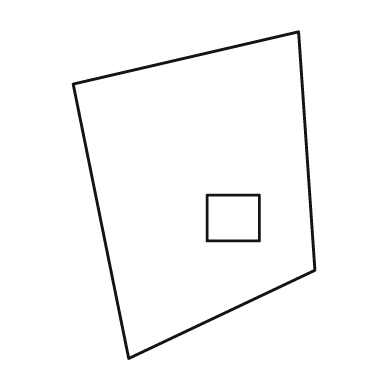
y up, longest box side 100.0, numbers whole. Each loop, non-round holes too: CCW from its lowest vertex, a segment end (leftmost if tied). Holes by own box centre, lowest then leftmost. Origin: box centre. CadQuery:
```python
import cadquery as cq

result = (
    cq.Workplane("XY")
    .moveTo(-20.0, -50.0)
    .lineTo(37.0, -23.0)
    .lineTo(32.0, 50.0)
    .lineTo(-37.0, 34.0)
    .close()
    .moveTo(4.0, -14.0)
    .lineTo(20.0, -14.0)
    .lineTo(20.0, 0.0)
    .lineTo(4.0, 0.0)
    .close()
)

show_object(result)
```